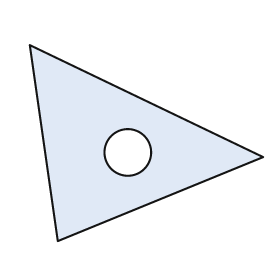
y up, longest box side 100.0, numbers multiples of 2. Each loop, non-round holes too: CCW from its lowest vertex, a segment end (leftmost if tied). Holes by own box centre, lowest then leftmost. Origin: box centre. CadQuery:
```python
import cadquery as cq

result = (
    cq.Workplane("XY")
    .moveTo(-38.0, -42.0)
    .lineTo(50.0, -6.0)
    .lineTo(-50.0, 42.0)
    .close()
    .moveTo(-8.0, -4.0)
    .circle(10.0)
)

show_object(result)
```